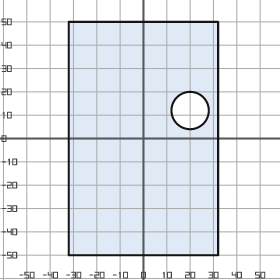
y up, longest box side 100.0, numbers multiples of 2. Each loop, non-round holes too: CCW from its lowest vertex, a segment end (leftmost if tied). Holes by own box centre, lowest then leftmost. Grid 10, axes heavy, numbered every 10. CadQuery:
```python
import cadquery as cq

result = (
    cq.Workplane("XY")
    .moveTo(-32.0, -50.0)
    .lineTo(32.0, -50.0)
    .lineTo(32.0, 50.0)
    .lineTo(-32.0, 50.0)
    .close()
    .moveTo(20.0, 12.0)
    .circle(8.0)
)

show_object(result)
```